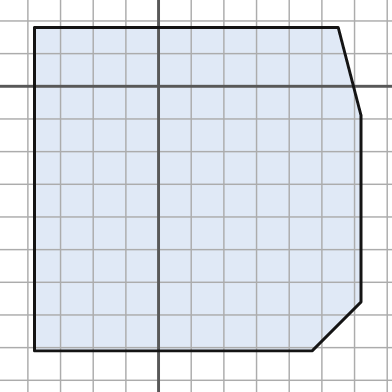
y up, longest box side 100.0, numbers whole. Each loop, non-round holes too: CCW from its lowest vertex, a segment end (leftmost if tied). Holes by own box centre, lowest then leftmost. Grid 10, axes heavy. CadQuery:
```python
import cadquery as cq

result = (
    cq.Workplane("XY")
    .moveTo(-38.0, -81.0)
    .lineTo(47.0, -81.0)
    .lineTo(62.0, -66.0)
    .lineTo(62.0, -9.0)
    .lineTo(55.0, 18.0)
    .lineTo(-38.0, 18.0)
    .close()
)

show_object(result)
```